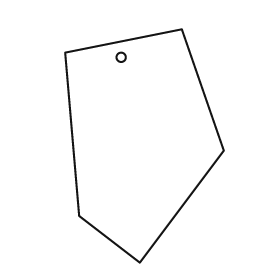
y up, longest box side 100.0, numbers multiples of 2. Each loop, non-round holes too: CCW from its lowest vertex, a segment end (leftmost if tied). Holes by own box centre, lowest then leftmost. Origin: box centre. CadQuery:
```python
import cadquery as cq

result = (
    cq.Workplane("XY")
    .moveTo(-2.0, -50.0)
    .lineTo(34.0, -2.0)
    .lineTo(16.0, 50.0)
    .lineTo(-34.0, 40.0)
    .lineTo(-28.0, -30.0)
    .close()
    .moveTo(-10.0, 38.0)
    .circle(2.0)
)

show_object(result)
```